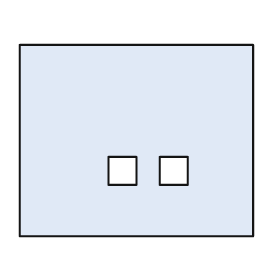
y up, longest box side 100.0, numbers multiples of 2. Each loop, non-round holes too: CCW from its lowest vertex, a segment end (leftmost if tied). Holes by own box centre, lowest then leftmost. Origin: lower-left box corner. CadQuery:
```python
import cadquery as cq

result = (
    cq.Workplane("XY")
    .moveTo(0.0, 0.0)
    .lineTo(100.0, 0.0)
    .lineTo(100.0, 82.0)
    .lineTo(0.0, 82.0)
    .close()
    .moveTo(38.0, 22.0)
    .lineTo(50.0, 22.0)
    .lineTo(50.0, 34.0)
    .lineTo(38.0, 34.0)
    .close()
    .moveTo(60.0, 22.0)
    .lineTo(72.0, 22.0)
    .lineTo(72.0, 34.0)
    .lineTo(60.0, 34.0)
    .close()
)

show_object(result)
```